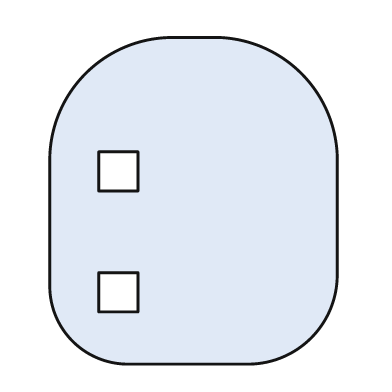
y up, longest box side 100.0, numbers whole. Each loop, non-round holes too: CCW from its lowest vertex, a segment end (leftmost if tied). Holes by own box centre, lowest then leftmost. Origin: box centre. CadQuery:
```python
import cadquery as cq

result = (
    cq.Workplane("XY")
    .moveTo(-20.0, -50.0)
    .lineTo(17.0, -50.0)
    .threePointArc((36.0, -42.0), (44.0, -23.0))
    .lineTo(44.0, 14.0)
    .threePointArc((33.0, 39.0), (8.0, 50.0))
    .lineTo(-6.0, 50.0)
    .threePointArc((-33.0, 39.0), (-44.0, 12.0))
    .lineTo(-44.0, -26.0)
    .threePointArc((-37.0, -43.0), (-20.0, -50.0))
    .close()
    .moveTo(-29.0, -34.0)
    .lineTo(-17.0, -34.0)
    .lineTo(-17.0, -22.0)
    .lineTo(-29.0, -22.0)
    .close()
    .moveTo(-29.0, 3.0)
    .lineTo(-17.0, 3.0)
    .lineTo(-17.0, 15.0)
    .lineTo(-29.0, 15.0)
    .close()
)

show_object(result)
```